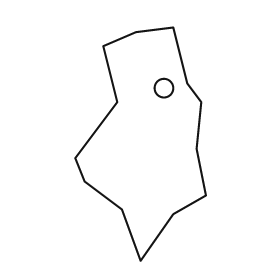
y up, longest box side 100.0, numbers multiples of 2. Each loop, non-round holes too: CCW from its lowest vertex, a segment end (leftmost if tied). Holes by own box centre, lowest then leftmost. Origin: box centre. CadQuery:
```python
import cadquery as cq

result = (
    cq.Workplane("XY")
    .moveTo(0.0, -50.0)
    .lineTo(14.0, -30.0)
    .lineTo(28.0, -22.0)
    .lineTo(24.0, -2.0)
    .lineTo(26.0, 18.0)
    .lineTo(20.0, 26.0)
    .lineTo(14.0, 50.0)
    .lineTo(-2.0, 48.0)
    .lineTo(-16.0, 42.0)
    .lineTo(-10.0, 18.0)
    .lineTo(-28.0, -6.0)
    .lineTo(-24.0, -16.0)
    .lineTo(-8.0, -28.0)
    .close()
    .moveTo(10.0, 24.0)
    .circle(4.0)
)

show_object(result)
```